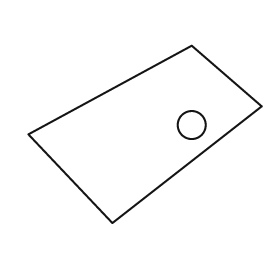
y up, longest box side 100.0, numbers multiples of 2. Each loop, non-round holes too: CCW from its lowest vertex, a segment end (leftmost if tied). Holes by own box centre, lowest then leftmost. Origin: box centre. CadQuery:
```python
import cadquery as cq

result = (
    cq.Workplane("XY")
    .moveTo(-14.0, -38.0)
    .lineTo(50.0, 12.0)
    .lineTo(20.0, 38.0)
    .lineTo(-50.0, 0.0)
    .close()
    .moveTo(20.0, 4.0)
    .circle(6.0)
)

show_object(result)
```